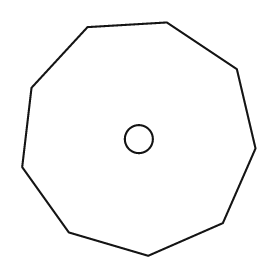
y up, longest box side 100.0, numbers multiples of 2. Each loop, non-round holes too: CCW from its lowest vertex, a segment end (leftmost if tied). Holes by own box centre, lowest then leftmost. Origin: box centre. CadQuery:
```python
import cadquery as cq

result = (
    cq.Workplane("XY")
    .moveTo(4.0, -50.0)
    .lineTo(36.0, -36.0)
    .lineTo(50.0, -4.0)
    .lineTo(42.0, 30.0)
    .lineTo(12.0, 50.0)
    .lineTo(-22.0, 48.0)
    .lineTo(-46.0, 22.0)
    .lineTo(-50.0, -12.0)
    .lineTo(-30.0, -40.0)
    .close()
    .moveTo(0.0, 0.0)
    .circle(6.0)
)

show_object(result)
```